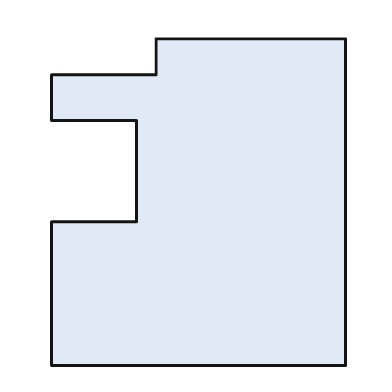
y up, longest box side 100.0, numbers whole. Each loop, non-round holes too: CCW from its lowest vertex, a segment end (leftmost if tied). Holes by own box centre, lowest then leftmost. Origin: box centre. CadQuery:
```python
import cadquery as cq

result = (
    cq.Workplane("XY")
    .moveTo(-45.0, -50.0)
    .lineTo(45.0, -50.0)
    .lineTo(45.0, 50.0)
    .lineTo(-13.0, 50.0)
    .lineTo(-13.0, 39.0)
    .lineTo(-45.0, 39.0)
    .lineTo(-45.0, 25.0)
    .lineTo(-19.0, 25.0)
    .lineTo(-19.0, -6.0)
    .lineTo(-45.0, -6.0)
    .close()
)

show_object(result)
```